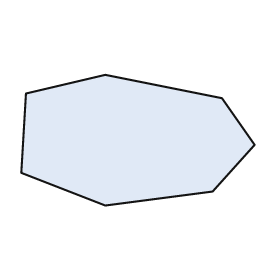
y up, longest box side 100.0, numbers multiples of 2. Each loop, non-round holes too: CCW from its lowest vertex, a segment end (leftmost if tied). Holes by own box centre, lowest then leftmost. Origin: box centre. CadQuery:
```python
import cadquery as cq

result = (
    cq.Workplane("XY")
    .moveTo(-14.0, -28.0)
    .lineTo(32.0, -22.0)
    .lineTo(50.0, -2.0)
    .lineTo(36.0, 18.0)
    .lineTo(-14.0, 28.0)
    .lineTo(-48.0, 20.0)
    .lineTo(-50.0, -14.0)
    .close()
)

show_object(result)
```